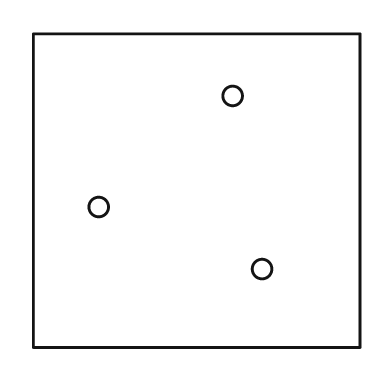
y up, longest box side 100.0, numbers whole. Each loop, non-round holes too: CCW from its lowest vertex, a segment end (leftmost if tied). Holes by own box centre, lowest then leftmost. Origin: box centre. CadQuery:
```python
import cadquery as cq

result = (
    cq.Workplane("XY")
    .moveTo(-50.0, -48.0)
    .lineTo(50.0, -48.0)
    .lineTo(50.0, 48.0)
    .lineTo(-50.0, 48.0)
    .close()
    .moveTo(20.0, -24.0)
    .circle(3.0)
    .moveTo(-30.0, -5.0)
    .circle(3.0)
    .moveTo(11.0, 29.0)
    .circle(3.0)
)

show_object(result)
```